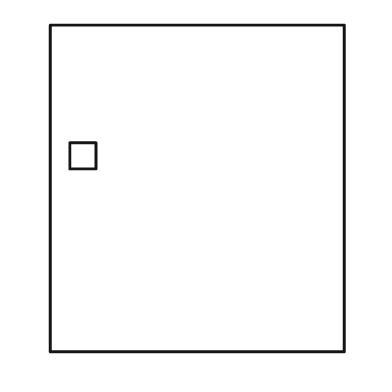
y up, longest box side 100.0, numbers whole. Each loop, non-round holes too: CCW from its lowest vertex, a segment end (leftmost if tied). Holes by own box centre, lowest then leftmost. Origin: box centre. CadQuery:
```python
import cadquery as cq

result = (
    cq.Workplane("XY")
    .moveTo(-45.0, -50.0)
    .lineTo(45.0, -50.0)
    .lineTo(45.0, 50.0)
    .lineTo(-45.0, 50.0)
    .close()
    .moveTo(-39.0, 6.0)
    .lineTo(-31.0, 6.0)
    .lineTo(-31.0, 14.0)
    .lineTo(-39.0, 14.0)
    .close()
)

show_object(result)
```